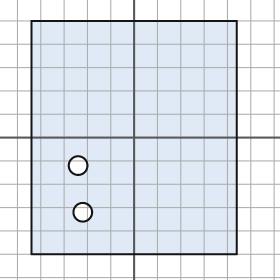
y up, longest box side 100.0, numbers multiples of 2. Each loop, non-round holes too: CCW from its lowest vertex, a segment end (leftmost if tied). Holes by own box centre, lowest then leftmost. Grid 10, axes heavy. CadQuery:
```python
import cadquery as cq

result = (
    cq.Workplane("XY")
    .moveTo(-44.0, -50.0)
    .lineTo(44.0, -50.0)
    .lineTo(44.0, 50.0)
    .lineTo(-44.0, 50.0)
    .close()
    .moveTo(-22.0, -32.0)
    .circle(4.0)
    .moveTo(-24.0, -12.0)
    .circle(4.0)
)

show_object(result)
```